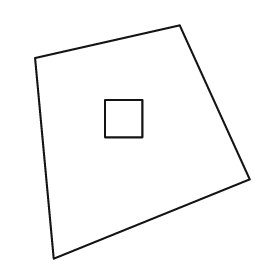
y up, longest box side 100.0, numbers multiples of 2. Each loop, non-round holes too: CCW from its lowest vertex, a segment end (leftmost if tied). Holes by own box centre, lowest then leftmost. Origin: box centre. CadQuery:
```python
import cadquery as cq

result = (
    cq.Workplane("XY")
    .moveTo(-38.0, -50.0)
    .lineTo(46.0, -16.0)
    .lineTo(16.0, 50.0)
    .lineTo(-46.0, 36.0)
    .close()
    .moveTo(-16.0, 2.0)
    .lineTo(0.0, 2.0)
    .lineTo(0.0, 18.0)
    .lineTo(-16.0, 18.0)
    .close()
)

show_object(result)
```